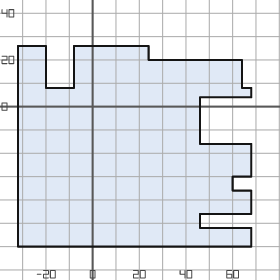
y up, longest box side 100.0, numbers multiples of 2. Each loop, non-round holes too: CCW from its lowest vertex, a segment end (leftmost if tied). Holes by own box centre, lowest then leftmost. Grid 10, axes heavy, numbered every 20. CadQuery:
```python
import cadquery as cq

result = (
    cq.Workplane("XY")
    .moveTo(-32.0, -60.0)
    .lineTo(68.0, -60.0)
    .lineTo(68.0, -52.0)
    .lineTo(46.0, -52.0)
    .lineTo(46.0, -46.0)
    .lineTo(68.0, -46.0)
    .lineTo(68.0, -36.0)
    .lineTo(60.0, -36.0)
    .lineTo(60.0, -30.0)
    .lineTo(68.0, -30.0)
    .lineTo(68.0, -16.0)
    .lineTo(46.0, -16.0)
    .lineTo(46.0, 4.0)
    .lineTo(68.0, 4.0)
    .lineTo(68.0, 8.0)
    .lineTo(64.0, 8.0)
    .lineTo(64.0, 20.0)
    .lineTo(24.0, 20.0)
    .lineTo(24.0, 26.0)
    .lineTo(-8.0, 26.0)
    .lineTo(-8.0, 8.0)
    .lineTo(-20.0, 8.0)
    .lineTo(-20.0, 26.0)
    .lineTo(-32.0, 26.0)
    .close()
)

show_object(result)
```